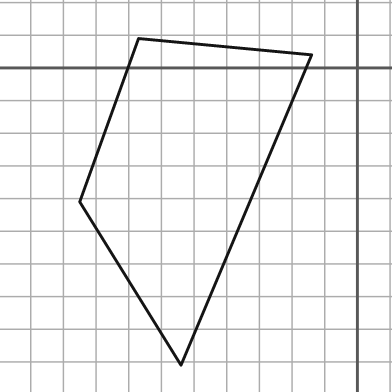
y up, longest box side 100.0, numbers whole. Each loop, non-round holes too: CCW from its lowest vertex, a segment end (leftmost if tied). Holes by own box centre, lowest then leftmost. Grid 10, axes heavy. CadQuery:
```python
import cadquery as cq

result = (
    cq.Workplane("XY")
    .moveTo(-54.0, -91.0)
    .lineTo(-14.0, 4.0)
    .lineTo(-67.0, 9.0)
    .lineTo(-85.0, -41.0)
    .close()
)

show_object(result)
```